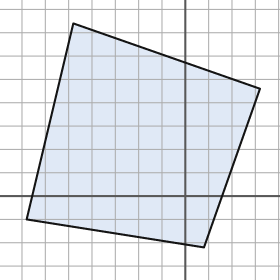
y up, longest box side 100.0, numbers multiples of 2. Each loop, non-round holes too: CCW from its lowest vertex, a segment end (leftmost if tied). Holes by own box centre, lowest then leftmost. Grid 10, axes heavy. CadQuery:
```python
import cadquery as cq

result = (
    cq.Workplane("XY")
    .moveTo(8.0, -22.0)
    .lineTo(32.0, 46.0)
    .lineTo(-48.0, 74.0)
    .lineTo(-68.0, -10.0)
    .close()
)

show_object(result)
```